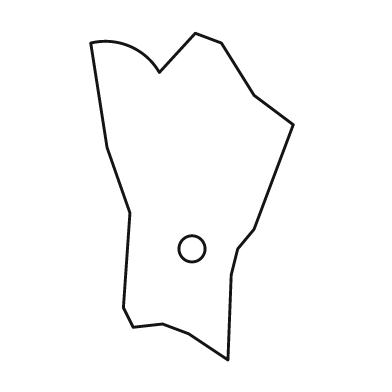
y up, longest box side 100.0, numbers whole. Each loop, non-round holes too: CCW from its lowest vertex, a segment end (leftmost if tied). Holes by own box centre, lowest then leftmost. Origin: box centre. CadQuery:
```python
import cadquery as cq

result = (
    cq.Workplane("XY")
    .moveTo(11.0, -50.0)
    .lineTo(12.0, -24.0)
    .lineTo(14.0, -16.0)
    .lineTo(19.0, -10.0)
    .lineTo(31.0, 22.0)
    .lineTo(19.0, 31.0)
    .lineTo(9.0, 47.0)
    .lineTo(1.0, 50.0)
    .lineTo(-10.0, 38.0)
    .threePointArc((-19.0, 46.0), (-31.0, 47.0))
    .lineTo(-26.0, 15.0)
    .lineTo(-19.0, -5.0)
    .lineTo(-21.0, -34.0)
    .lineTo(-18.0, -40.0)
    .lineTo(-9.0, -39.0)
    .lineTo(-1.0, -42.0)
    .close()
    .moveTo(0.0, -16.0)
    .circle(4.0)
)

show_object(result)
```